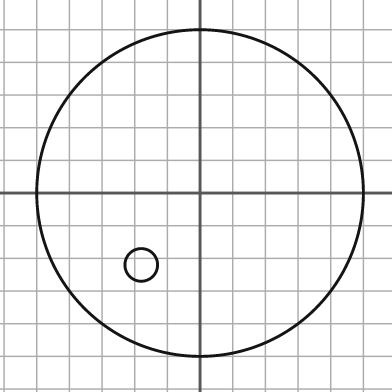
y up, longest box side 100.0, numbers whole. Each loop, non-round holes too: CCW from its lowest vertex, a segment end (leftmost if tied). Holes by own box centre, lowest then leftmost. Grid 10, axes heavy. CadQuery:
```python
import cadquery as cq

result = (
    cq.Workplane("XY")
    .moveTo(0.0, 0.0)
    .circle(50.0)
    .moveTo(-18.0, -22.0)
    .circle(5.0)
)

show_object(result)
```